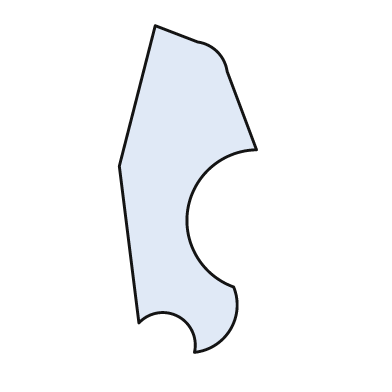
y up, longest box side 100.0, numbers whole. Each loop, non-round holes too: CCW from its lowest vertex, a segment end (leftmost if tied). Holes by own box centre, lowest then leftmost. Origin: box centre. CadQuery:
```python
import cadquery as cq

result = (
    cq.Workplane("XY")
    .moveTo(2.0, -50.0)
    .threePointArc((13.0, -43.0), (14.0, -30.0))
    .threePointArc((0.0, -6.0), (21.0, 12.0))
    .lineTo(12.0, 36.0)
    .threePointArc((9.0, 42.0), (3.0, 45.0))
    .lineTo(-10.0, 50.0)
    .lineTo(-21.0, 7.0)
    .lineTo(-15.0, -41.0)
    .threePointArc((-3.0, -39.0), (2.0, -50.0))
    .close()
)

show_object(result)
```